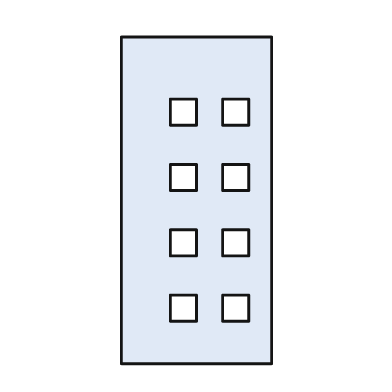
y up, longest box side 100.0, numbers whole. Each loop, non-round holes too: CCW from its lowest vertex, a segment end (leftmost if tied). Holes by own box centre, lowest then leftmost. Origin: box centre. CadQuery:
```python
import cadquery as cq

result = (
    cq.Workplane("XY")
    .moveTo(-23.0, -50.0)
    .lineTo(23.0, -50.0)
    .lineTo(23.0, 50.0)
    .lineTo(-23.0, 50.0)
    .close()
    .moveTo(-8.0, -37.0)
    .lineTo(0.0, -37.0)
    .lineTo(0.0, -29.0)
    .lineTo(-8.0, -29.0)
    .close()
    .moveTo(8.0, -37.0)
    .lineTo(16.0, -37.0)
    .lineTo(16.0, -29.0)
    .lineTo(8.0, -29.0)
    .close()
    .moveTo(-8.0, -17.0)
    .lineTo(0.0, -17.0)
    .lineTo(0.0, -9.0)
    .lineTo(-8.0, -9.0)
    .close()
    .moveTo(8.0, -17.0)
    .lineTo(16.0, -17.0)
    .lineTo(16.0, -9.0)
    .lineTo(8.0, -9.0)
    .close()
    .moveTo(-8.0, 3.0)
    .lineTo(0.0, 3.0)
    .lineTo(0.0, 11.0)
    .lineTo(-8.0, 11.0)
    .close()
    .moveTo(8.0, 3.0)
    .lineTo(16.0, 3.0)
    .lineTo(16.0, 11.0)
    .lineTo(8.0, 11.0)
    .close()
    .moveTo(-8.0, 23.0)
    .lineTo(0.0, 23.0)
    .lineTo(0.0, 31.0)
    .lineTo(-8.0, 31.0)
    .close()
    .moveTo(8.0, 23.0)
    .lineTo(16.0, 23.0)
    .lineTo(16.0, 31.0)
    .lineTo(8.0, 31.0)
    .close()
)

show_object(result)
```